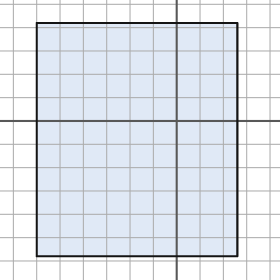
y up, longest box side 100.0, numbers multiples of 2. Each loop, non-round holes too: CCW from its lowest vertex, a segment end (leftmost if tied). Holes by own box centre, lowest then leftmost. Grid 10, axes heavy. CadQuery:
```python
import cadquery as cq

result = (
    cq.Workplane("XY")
    .moveTo(-60.0, -58.0)
    .lineTo(26.0, -58.0)
    .lineTo(26.0, 42.0)
    .lineTo(-60.0, 42.0)
    .close()
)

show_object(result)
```